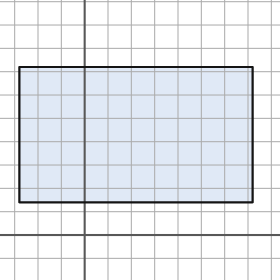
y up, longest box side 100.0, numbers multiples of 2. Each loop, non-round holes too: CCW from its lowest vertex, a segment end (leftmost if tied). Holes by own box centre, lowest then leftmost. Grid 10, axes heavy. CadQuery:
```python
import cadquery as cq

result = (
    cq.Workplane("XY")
    .moveTo(-28.0, 14.0)
    .lineTo(72.0, 14.0)
    .lineTo(72.0, 72.0)
    .lineTo(-28.0, 72.0)
    .close()
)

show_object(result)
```